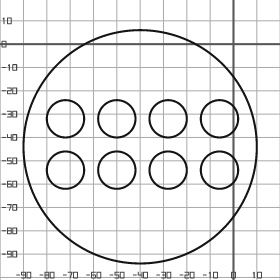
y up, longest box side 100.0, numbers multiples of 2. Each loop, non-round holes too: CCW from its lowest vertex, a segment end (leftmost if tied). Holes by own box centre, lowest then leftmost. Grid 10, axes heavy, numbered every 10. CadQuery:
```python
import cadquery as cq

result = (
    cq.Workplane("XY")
    .moveTo(-40.0, -44.0)
    .circle(50.0)
    .moveTo(-72.0, -54.0)
    .circle(8.0)
    .moveTo(-50.0, -54.0)
    .circle(8.0)
    .moveTo(-28.0, -54.0)
    .circle(8.0)
    .moveTo(-6.0, -54.0)
    .circle(8.0)
    .moveTo(-72.0, -32.0)
    .circle(8.0)
    .moveTo(-50.0, -32.0)
    .circle(8.0)
    .moveTo(-28.0, -32.0)
    .circle(8.0)
    .moveTo(-6.0, -32.0)
    .circle(8.0)
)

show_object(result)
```